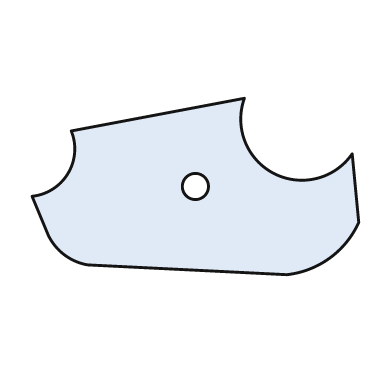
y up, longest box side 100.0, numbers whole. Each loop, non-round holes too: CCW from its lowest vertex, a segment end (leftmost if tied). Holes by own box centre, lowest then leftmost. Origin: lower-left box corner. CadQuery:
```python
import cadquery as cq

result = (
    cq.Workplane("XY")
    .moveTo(78.0, 0.0)
    .threePointArc((91.0, 5.0), (100.0, 16.0))
    .lineTo(98.0, 37.0)
    .threePointArc((74.0, 31.0), (65.0, 54.0))
    .lineTo(12.0, 44.0)
    .threePointArc((11.0, 31.0), (0.0, 24.0))
    .lineTo(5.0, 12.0)
    .threePointArc((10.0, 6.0), (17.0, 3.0))
    .close()
    .moveTo(50.0, 27.0)
    .circle(4.0)
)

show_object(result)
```